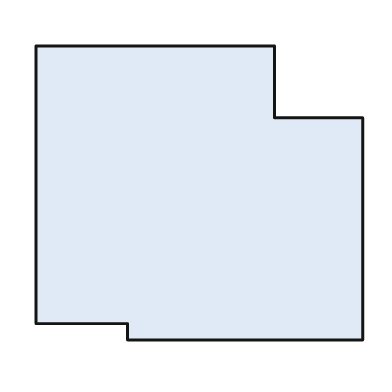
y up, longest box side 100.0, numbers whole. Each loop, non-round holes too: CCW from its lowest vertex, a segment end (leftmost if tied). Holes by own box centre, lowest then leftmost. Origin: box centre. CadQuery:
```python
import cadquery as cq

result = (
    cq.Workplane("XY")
    .moveTo(-22.0, -45.0)
    .lineTo(50.0, -45.0)
    .lineTo(50.0, 23.0)
    .lineTo(23.0, 23.0)
    .lineTo(23.0, 45.0)
    .lineTo(-50.0, 45.0)
    .lineTo(-50.0, -40.0)
    .lineTo(-22.0, -40.0)
    .close()
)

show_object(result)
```